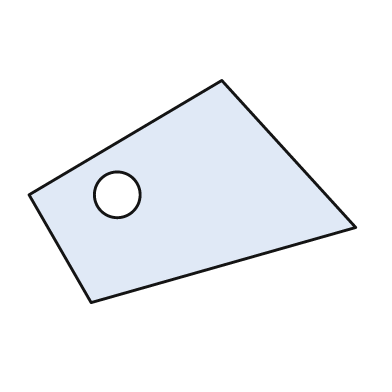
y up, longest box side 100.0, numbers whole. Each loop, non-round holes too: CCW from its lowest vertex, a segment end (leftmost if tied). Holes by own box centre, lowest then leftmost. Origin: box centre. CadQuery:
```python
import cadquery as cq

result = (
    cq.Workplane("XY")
    .moveTo(-31.0, -34.0)
    .lineTo(50.0, -11.0)
    .lineTo(9.0, 34.0)
    .lineTo(-50.0, -1.0)
    .close()
    .moveTo(-23.0, -1.0)
    .circle(7.0)
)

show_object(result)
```